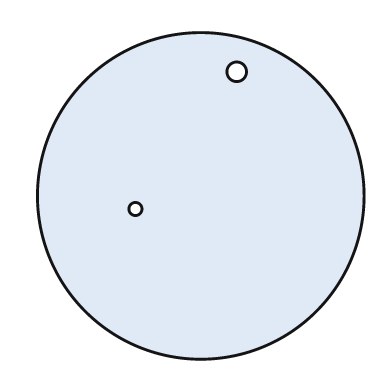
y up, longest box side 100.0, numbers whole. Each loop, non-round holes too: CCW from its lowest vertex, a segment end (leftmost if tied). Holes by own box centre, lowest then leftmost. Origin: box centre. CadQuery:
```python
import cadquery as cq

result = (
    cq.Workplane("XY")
    .moveTo(0.0, 0.0)
    .circle(50.0)
    .moveTo(-20.0, -4.0)
    .circle(2.0)
    .moveTo(11.0, 38.0)
    .circle(3.0)
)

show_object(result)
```